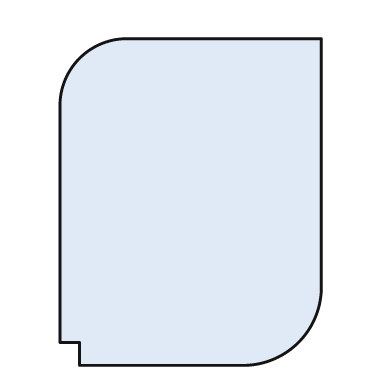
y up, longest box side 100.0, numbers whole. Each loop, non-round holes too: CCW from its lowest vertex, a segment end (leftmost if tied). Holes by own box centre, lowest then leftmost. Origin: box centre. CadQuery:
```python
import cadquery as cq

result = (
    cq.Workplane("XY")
    .moveTo(-34.0, -50.0)
    .lineTo(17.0, -50.0)
    .threePointArc((33.0, -43.0), (40.0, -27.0))
    .lineTo(40.0, 50.0)
    .lineTo(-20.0, 50.0)
    .threePointArc((-34.0, 44.0), (-40.0, 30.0))
    .lineTo(-40.0, -43.0)
    .lineTo(-34.0, -43.0)
    .close()
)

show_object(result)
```